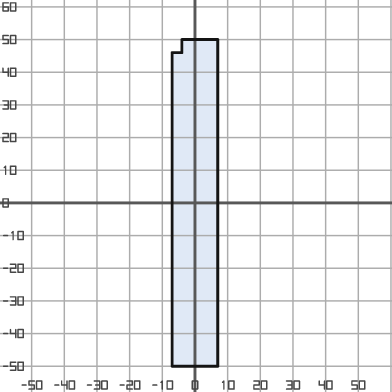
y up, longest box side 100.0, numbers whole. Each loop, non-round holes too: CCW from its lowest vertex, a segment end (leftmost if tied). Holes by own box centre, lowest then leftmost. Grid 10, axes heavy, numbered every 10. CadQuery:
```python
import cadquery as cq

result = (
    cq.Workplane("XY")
    .moveTo(-7.0, -50.0)
    .lineTo(7.0, -50.0)
    .lineTo(7.0, 50.0)
    .lineTo(-4.0, 50.0)
    .lineTo(-4.0, 46.0)
    .lineTo(-7.0, 46.0)
    .close()
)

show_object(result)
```